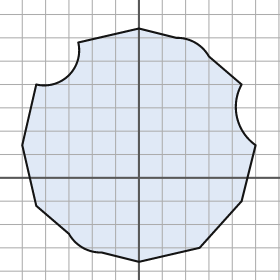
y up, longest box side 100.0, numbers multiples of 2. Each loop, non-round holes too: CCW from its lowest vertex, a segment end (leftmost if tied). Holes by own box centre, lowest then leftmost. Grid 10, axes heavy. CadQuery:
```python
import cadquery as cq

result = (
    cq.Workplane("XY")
    .moveTo(0.0, -36.0)
    .lineTo(26.0, -30.0)
    .lineTo(44.0, -10.0)
    .lineTo(50.0, 14.0)
    .threePointArc((42.0, 26.0), (44.0, 40.0))
    .lineTo(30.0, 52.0)
    .threePointArc((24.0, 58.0), (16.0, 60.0))
    .lineTo(0.0, 64.0)
    .lineTo(-26.0, 58.0)
    .threePointArc((-30.0, 44.0), (-44.0, 40.0))
    .lineTo(-50.0, 14.0)
    .lineTo(-44.0, -12.0)
    .lineTo(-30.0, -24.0)
    .threePointArc((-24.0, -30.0), (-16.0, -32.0))
    .close()
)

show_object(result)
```